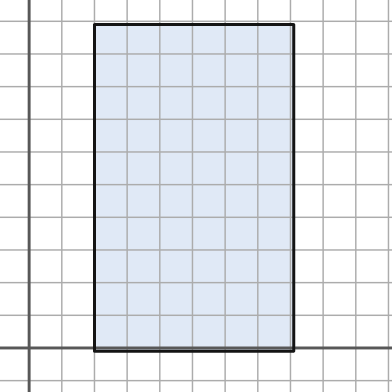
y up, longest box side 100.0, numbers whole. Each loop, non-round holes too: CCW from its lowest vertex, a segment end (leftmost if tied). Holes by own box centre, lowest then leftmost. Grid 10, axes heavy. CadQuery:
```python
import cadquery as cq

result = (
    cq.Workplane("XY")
    .moveTo(20.0, -1.0)
    .lineTo(81.0, -1.0)
    .lineTo(81.0, 99.0)
    .lineTo(20.0, 99.0)
    .close()
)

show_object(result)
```